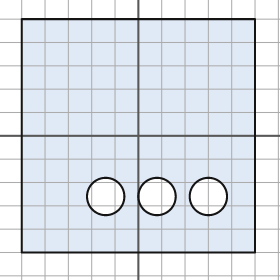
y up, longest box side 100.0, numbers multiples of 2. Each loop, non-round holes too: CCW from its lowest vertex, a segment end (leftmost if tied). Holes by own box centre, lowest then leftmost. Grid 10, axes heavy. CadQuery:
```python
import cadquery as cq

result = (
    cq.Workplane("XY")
    .moveTo(-50.0, -50.0)
    .lineTo(50.0, -50.0)
    .lineTo(50.0, 50.0)
    .lineTo(-50.0, 50.0)
    .close()
    .moveTo(-14.0, -26.0)
    .circle(8.0)
    .moveTo(8.0, -26.0)
    .circle(8.0)
    .moveTo(30.0, -26.0)
    .circle(8.0)
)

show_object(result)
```